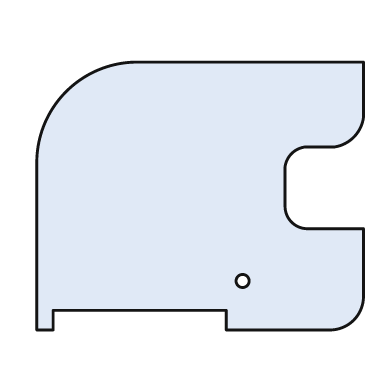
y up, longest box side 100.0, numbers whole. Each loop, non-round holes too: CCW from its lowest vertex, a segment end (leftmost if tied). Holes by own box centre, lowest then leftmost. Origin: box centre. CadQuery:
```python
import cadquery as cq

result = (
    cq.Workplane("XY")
    .moveTo(-50.0, -41.0)
    .lineTo(-45.0, -41.0)
    .lineTo(-45.0, -35.0)
    .lineTo(8.0, -35.0)
    .lineTo(8.0, -41.0)
    .lineTo(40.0, -41.0)
    .threePointArc((47.0, -38.0), (50.0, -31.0))
    .lineTo(50.0, -10.0)
    .lineTo(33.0, -10.0)
    .threePointArc((28.0, -8.0), (26.0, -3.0))
    .lineTo(26.0, 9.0)
    .threePointArc((28.0, 13.0), (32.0, 15.0))
    .lineTo(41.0, 15.0)
    .threePointArc((47.0, 18.0), (50.0, 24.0))
    .lineTo(50.0, 41.0)
    .lineTo(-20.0, 41.0)
    .threePointArc((-41.0, 32.0), (-50.0, 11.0))
    .close()
    .moveTo(13.0, -26.0)
    .circle(2.0)
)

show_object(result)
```